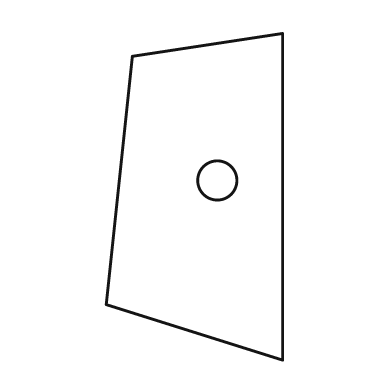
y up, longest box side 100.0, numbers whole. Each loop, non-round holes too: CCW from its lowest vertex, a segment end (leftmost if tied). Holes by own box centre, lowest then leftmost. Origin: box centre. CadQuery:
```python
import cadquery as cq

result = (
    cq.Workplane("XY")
    .moveTo(27.0, -50.0)
    .lineTo(27.0, 50.0)
    .lineTo(-19.0, 43.0)
    .lineTo(-27.0, -33.0)
    .close()
    .moveTo(7.0, 5.0)
    .circle(6.0)
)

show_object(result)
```